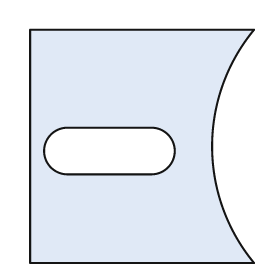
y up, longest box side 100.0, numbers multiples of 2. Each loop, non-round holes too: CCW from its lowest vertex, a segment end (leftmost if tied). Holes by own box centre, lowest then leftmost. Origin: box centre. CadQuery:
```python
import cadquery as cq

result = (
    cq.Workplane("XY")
    .moveTo(-48.0, -50.0)
    .lineTo(48.0, -50.0)
    .threePointArc((30.0, 0.0), (48.0, 50.0))
    .lineTo(-48.0, 50.0)
    .close()
    .moveTo(-32.0, -12.0)
    .lineTo(4.0, -12.0)
    .threePointArc((14.0, -2.0), (4.0, 8.0))
    .lineTo(-32.0, 8.0)
    .threePointArc((-42.0, -2.0), (-32.0, -12.0))
    .close()
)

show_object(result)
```